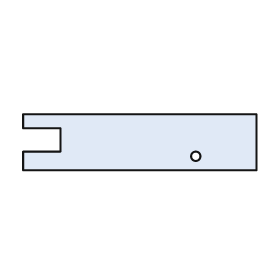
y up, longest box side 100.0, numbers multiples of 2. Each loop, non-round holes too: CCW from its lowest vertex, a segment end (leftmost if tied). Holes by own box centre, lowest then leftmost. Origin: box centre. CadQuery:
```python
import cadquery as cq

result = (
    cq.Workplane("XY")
    .moveTo(-50.0, -12.0)
    .lineTo(50.0, -12.0)
    .lineTo(50.0, 12.0)
    .lineTo(-50.0, 12.0)
    .lineTo(-50.0, 6.0)
    .lineTo(-34.0, 6.0)
    .lineTo(-34.0, -4.0)
    .lineTo(-50.0, -4.0)
    .close()
    .moveTo(24.0, -6.0)
    .circle(2.0)
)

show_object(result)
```